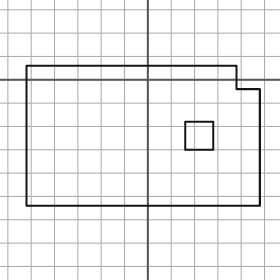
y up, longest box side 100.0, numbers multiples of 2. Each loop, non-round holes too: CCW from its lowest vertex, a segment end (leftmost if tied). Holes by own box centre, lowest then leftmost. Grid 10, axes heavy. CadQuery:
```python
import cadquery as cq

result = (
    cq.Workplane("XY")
    .moveTo(-52.0, -54.0)
    .lineTo(48.0, -54.0)
    .lineTo(48.0, -4.0)
    .lineTo(38.0, -4.0)
    .lineTo(38.0, 6.0)
    .lineTo(-52.0, 6.0)
    .close()
    .moveTo(16.0, -30.0)
    .lineTo(28.0, -30.0)
    .lineTo(28.0, -18.0)
    .lineTo(16.0, -18.0)
    .close()
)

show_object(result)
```